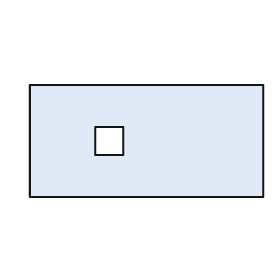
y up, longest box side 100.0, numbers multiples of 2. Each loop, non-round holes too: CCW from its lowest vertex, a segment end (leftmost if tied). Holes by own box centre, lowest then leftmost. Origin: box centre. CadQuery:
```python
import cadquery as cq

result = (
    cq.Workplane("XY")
    .moveTo(-50.0, -24.0)
    .lineTo(50.0, -24.0)
    .lineTo(50.0, 24.0)
    .lineTo(-50.0, 24.0)
    .close()
    .moveTo(-22.0, -6.0)
    .lineTo(-10.0, -6.0)
    .lineTo(-10.0, 6.0)
    .lineTo(-22.0, 6.0)
    .close()
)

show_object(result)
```